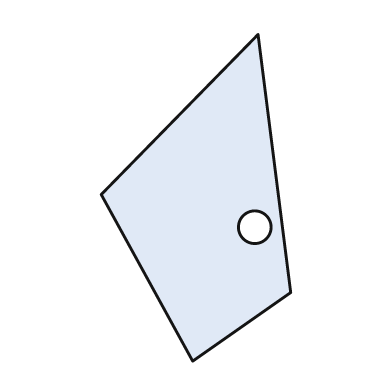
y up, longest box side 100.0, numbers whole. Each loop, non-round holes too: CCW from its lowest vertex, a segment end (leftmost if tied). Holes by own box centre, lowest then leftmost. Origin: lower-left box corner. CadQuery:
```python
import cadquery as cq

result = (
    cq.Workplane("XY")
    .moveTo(28.0, 0.0)
    .lineTo(58.0, 21.0)
    .lineTo(48.0, 100.0)
    .lineTo(0.0, 51.0)
    .close()
    .moveTo(47.0, 41.0)
    .circle(5.0)
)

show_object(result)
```